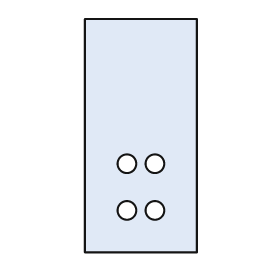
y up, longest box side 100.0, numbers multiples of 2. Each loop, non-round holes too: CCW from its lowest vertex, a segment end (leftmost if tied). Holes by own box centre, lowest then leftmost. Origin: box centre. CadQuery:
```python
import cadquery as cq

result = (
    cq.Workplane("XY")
    .moveTo(-24.0, -50.0)
    .lineTo(24.0, -50.0)
    .lineTo(24.0, 50.0)
    .lineTo(-24.0, 50.0)
    .close()
    .moveTo(-6.0, -32.0)
    .circle(4.0)
    .moveTo(6.0, -32.0)
    .circle(4.0)
    .moveTo(-6.0, -12.0)
    .circle(4.0)
    .moveTo(6.0, -12.0)
    .circle(4.0)
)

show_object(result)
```